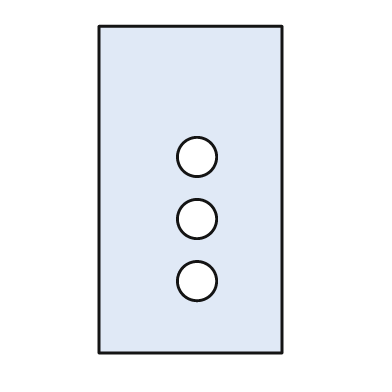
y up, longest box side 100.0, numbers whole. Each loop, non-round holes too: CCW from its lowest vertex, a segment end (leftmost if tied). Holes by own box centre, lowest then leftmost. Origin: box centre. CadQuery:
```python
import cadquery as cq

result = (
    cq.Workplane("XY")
    .moveTo(-28.0, -50.0)
    .lineTo(28.0, -50.0)
    .lineTo(28.0, 50.0)
    .lineTo(-28.0, 50.0)
    .close()
    .moveTo(2.0, -28.0)
    .circle(6.0)
    .moveTo(2.0, -9.0)
    .circle(6.0)
    .moveTo(2.0, 10.0)
    .circle(6.0)
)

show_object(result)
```